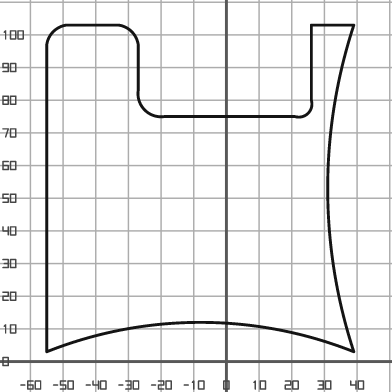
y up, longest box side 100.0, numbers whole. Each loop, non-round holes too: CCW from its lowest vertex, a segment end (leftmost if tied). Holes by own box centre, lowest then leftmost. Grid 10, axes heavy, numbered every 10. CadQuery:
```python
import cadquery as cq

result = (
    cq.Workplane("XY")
    .moveTo(-55.0, 3.0)
    .threePointArc((-8.0, 12.0), (39.0, 3.0))
    .threePointArc((31.0, 53.0), (39.0, 103.0))
    .lineTo(26.0, 103.0)
    .lineTo(26.0, 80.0)
    .threePointArc((25.0, 76.0), (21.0, 75.0))
    .lineTo(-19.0, 75.0)
    .threePointArc((-25.0, 77.0), (-27.0, 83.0))
    .lineTo(-27.0, 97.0)
    .threePointArc((-29.0, 101.0), (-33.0, 103.0))
    .lineTo(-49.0, 103.0)
    .threePointArc((-53.0, 101.0), (-55.0, 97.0))
    .close()
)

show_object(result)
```